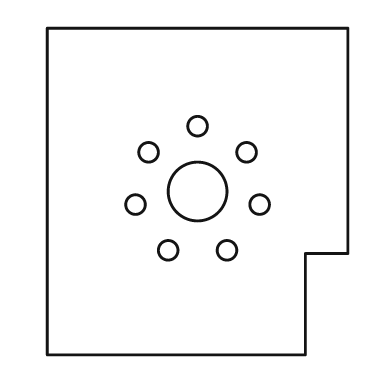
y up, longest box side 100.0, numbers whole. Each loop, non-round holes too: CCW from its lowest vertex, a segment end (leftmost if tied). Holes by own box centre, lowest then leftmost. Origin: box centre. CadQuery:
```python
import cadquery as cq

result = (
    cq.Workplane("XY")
    .moveTo(-46.0, -50.0)
    .lineTo(33.0, -50.0)
    .lineTo(33.0, -19.0)
    .lineTo(46.0, -19.0)
    .lineTo(46.0, 50.0)
    .lineTo(-46.0, 50.0)
    .close()
    .moveTo(-9.0, -18.0)
    .circle(3.0)
    .moveTo(9.0, -18.0)
    .circle(3.0)
    .moveTo(-19.0, -4.0)
    .circle(3.0)
    .moveTo(19.0, -4.0)
    .circle(3.0)
    .moveTo(0.0, 0.0)
    .circle(9.0)
    .moveTo(-15.0, 12.0)
    .circle(3.0)
    .moveTo(15.0, 12.0)
    .circle(3.0)
    .moveTo(0.0, 20.0)
    .circle(3.0)
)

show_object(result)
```